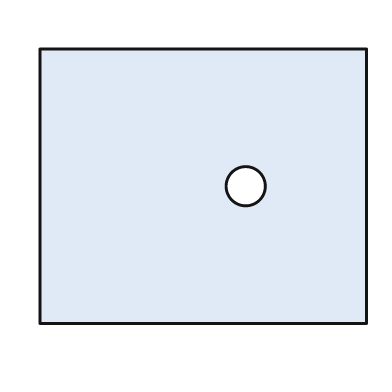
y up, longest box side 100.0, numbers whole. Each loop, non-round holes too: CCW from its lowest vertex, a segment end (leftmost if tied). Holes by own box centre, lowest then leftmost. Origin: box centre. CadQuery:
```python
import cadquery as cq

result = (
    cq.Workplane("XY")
    .moveTo(-50.0, -42.0)
    .lineTo(50.0, -42.0)
    .lineTo(50.0, 42.0)
    .lineTo(-50.0, 42.0)
    .close()
    .moveTo(13.0, 0.0)
    .circle(6.0)
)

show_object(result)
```